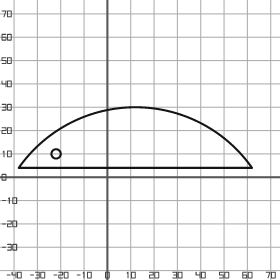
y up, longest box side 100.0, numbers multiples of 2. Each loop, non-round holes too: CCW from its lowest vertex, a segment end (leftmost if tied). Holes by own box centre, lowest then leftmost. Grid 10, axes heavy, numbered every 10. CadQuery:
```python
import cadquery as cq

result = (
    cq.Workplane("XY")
    .moveTo(-38.0, 4.0)
    .lineTo(62.0, 4.0)
    .threePointArc((12.0, 30.0), (-38.0, 4.0))
    .close()
    .moveTo(-22.0, 10.0)
    .circle(2.0)
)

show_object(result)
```